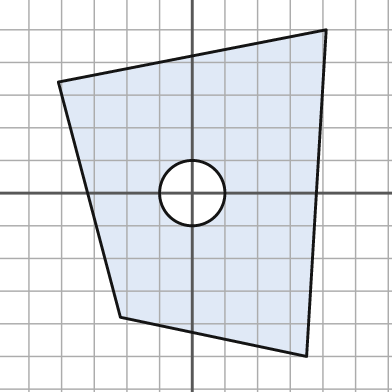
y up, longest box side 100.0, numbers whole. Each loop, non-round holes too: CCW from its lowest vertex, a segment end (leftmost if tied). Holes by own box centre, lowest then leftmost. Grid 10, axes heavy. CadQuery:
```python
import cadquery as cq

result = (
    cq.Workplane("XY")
    .moveTo(35.0, -50.0)
    .lineTo(41.0, 50.0)
    .lineTo(-41.0, 34.0)
    .lineTo(-22.0, -38.0)
    .close()
    .moveTo(0.0, 0.0)
    .circle(10.0)
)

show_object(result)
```